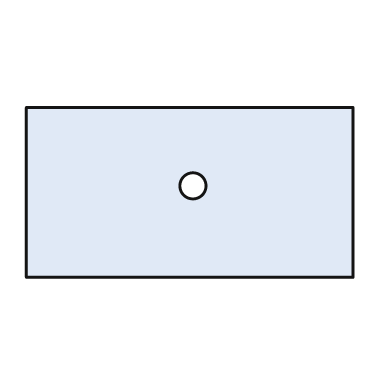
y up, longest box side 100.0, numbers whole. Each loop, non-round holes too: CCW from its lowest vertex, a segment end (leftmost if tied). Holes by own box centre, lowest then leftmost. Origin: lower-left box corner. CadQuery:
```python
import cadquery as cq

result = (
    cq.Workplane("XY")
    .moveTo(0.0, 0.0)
    .lineTo(100.0, 0.0)
    .lineTo(100.0, 52.0)
    .lineTo(0.0, 52.0)
    .close()
    .moveTo(51.0, 28.0)
    .circle(4.0)
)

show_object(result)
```